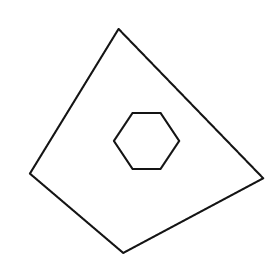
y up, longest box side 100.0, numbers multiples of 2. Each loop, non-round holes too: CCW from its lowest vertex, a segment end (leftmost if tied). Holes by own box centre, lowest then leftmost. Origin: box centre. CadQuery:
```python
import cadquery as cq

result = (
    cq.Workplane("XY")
    .moveTo(-10.0, -48.0)
    .lineTo(50.0, -16.0)
    .lineTo(-12.0, 48.0)
    .lineTo(-50.0, -14.0)
    .close()
    .moveTo(-6.0, -12.0)
    .lineTo(6.0, -12.0)
    .lineTo(14.0, 0.0)
    .lineTo(6.0, 12.0)
    .lineTo(-6.0, 12.0)
    .lineTo(-14.0, 0.0)
    .close()
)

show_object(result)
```